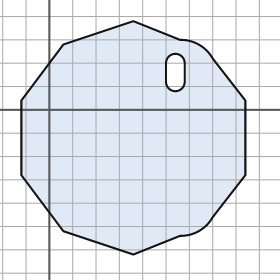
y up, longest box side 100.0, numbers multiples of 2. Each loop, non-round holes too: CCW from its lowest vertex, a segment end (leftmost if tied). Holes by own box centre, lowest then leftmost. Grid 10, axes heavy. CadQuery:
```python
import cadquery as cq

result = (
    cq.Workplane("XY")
    .moveTo(36.0, -62.0)
    .lineTo(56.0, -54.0)
    .threePointArc((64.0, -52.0), (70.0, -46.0))
    .lineTo(84.0, -28.0)
    .lineTo(84.0, 4.0)
    .lineTo(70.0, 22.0)
    .threePointArc((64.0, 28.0), (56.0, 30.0))
    .lineTo(36.0, 38.0)
    .lineTo(6.0, 28.0)
    .lineTo(-12.0, 4.0)
    .lineTo(-12.0, -28.0)
    .lineTo(6.0, -52.0)
    .close()
    .moveTo(50.0, 12.0)
    .threePointArc((54.0, 8.0), (58.0, 12.0))
    .lineTo(58.0, 20.0)
    .threePointArc((54.0, 24.0), (50.0, 20.0))
    .close()
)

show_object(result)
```